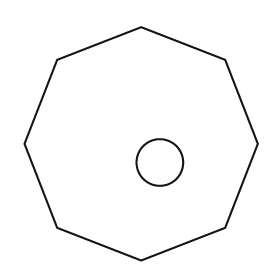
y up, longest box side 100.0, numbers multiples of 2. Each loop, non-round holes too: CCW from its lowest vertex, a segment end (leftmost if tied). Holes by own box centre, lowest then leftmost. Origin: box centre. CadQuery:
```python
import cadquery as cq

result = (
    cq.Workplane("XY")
    .moveTo(0.0, -50.0)
    .lineTo(36.0, -36.0)
    .lineTo(50.0, 0.0)
    .lineTo(36.0, 36.0)
    .lineTo(0.0, 50.0)
    .lineTo(-36.0, 36.0)
    .lineTo(-50.0, 0.0)
    .lineTo(-36.0, -36.0)
    .close()
    .moveTo(8.0, -8.0)
    .circle(10.0)
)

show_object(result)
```